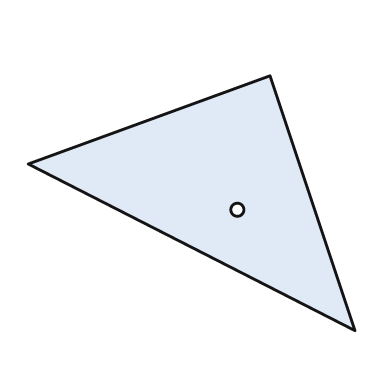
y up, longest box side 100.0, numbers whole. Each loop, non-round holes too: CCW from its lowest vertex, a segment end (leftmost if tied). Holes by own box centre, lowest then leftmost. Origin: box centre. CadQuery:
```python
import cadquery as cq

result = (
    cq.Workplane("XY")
    .moveTo(50.0, -39.0)
    .lineTo(24.0, 39.0)
    .lineTo(-50.0, 12.0)
    .close()
    .moveTo(14.0, -2.0)
    .circle(2.0)
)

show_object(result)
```